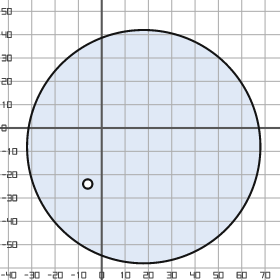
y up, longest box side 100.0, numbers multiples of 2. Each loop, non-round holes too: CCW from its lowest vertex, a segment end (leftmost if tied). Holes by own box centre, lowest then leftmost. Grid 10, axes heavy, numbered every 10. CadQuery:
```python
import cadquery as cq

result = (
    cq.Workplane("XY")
    .moveTo(18.0, -8.0)
    .circle(50.0)
    .moveTo(-6.0, -24.0)
    .circle(2.0)
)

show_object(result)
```